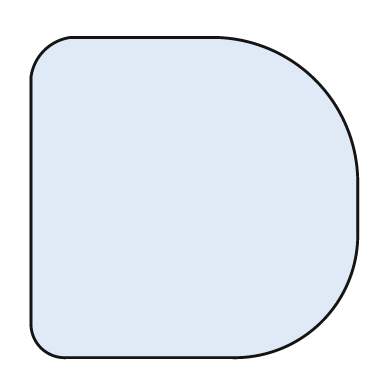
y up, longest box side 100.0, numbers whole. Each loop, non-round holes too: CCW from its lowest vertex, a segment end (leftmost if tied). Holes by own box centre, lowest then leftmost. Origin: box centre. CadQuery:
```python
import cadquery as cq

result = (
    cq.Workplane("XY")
    .moveTo(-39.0, -49.0)
    .lineTo(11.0, -49.0)
    .threePointArc((39.0, -38.0), (50.0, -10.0))
    .lineTo(50.0, 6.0)
    .threePointArc((37.0, 36.0), (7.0, 49.0))
    .lineTo(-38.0, 49.0)
    .threePointArc((-46.0, 45.0), (-50.0, 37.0))
    .lineTo(-50.0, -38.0)
    .threePointArc((-47.0, -46.0), (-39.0, -49.0))
    .close()
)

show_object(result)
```